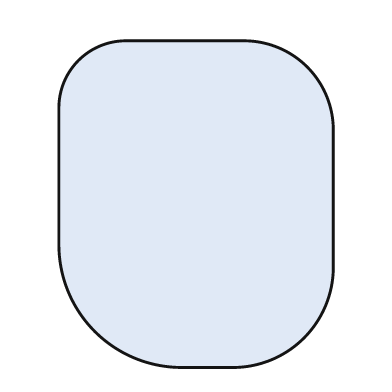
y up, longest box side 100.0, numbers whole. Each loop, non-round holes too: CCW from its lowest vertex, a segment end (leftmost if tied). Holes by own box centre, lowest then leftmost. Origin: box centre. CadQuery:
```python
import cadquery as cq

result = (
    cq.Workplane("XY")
    .moveTo(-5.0, -50.0)
    .lineTo(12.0, -50.0)
    .threePointArc((33.0, -41.0), (42.0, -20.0))
    .lineTo(42.0, 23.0)
    .threePointArc((34.0, 42.0), (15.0, 50.0))
    .lineTo(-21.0, 50.0)
    .threePointArc((-36.0, 44.0), (-42.0, 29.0))
    .lineTo(-42.0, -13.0)
    .threePointArc((-31.0, -39.0), (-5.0, -50.0))
    .close()
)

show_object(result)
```